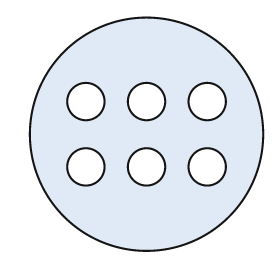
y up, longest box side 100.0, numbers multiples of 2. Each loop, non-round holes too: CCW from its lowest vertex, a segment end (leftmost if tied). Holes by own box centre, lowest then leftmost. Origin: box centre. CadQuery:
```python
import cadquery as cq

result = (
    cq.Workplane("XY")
    .moveTo(0.0, 0.0)
    .circle(50.0)
    .moveTo(-26.0, -14.0)
    .circle(8.0)
    .moveTo(0.0, -14.0)
    .circle(8.0)
    .moveTo(26.0, -14.0)
    .circle(8.0)
    .moveTo(-26.0, 14.0)
    .circle(8.0)
    .moveTo(0.0, 14.0)
    .circle(8.0)
    .moveTo(26.0, 14.0)
    .circle(8.0)
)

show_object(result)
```